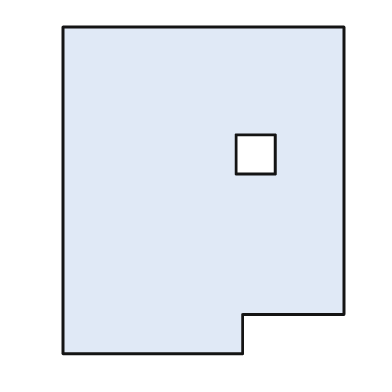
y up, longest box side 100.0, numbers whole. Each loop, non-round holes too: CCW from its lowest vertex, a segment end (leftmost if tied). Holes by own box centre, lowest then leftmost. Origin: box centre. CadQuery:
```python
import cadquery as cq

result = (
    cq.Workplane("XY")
    .moveTo(-43.0, -50.0)
    .lineTo(12.0, -50.0)
    .lineTo(12.0, -38.0)
    .lineTo(43.0, -38.0)
    .lineTo(43.0, 50.0)
    .lineTo(-43.0, 50.0)
    .close()
    .moveTo(10.0, 5.0)
    .lineTo(22.0, 5.0)
    .lineTo(22.0, 17.0)
    .lineTo(10.0, 17.0)
    .close()
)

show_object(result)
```